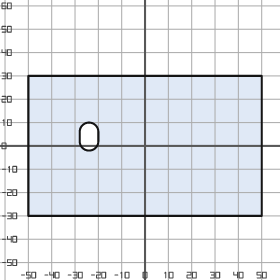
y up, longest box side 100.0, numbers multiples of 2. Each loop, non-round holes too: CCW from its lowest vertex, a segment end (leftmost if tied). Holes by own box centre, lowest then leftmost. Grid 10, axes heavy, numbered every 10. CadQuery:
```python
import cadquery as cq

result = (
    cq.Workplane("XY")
    .moveTo(-50.0, -30.0)
    .lineTo(50.0, -30.0)
    .lineTo(50.0, 30.0)
    .lineTo(-50.0, 30.0)
    .close()
    .moveTo(-28.0, 2.0)
    .threePointArc((-24.0, -2.0), (-20.0, 2.0))
    .lineTo(-20.0, 6.0)
    .threePointArc((-24.0, 10.0), (-28.0, 6.0))
    .close()
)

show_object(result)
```